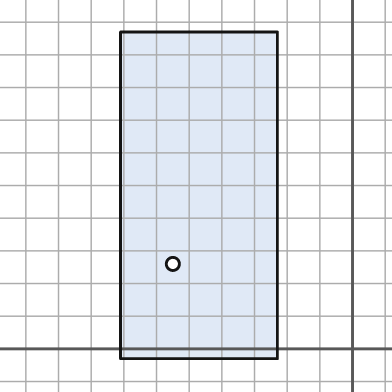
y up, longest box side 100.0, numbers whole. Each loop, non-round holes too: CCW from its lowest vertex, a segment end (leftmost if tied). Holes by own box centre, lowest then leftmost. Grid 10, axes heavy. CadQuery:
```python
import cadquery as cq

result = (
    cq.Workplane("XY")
    .moveTo(-71.0, -3.0)
    .lineTo(-23.0, -3.0)
    .lineTo(-23.0, 97.0)
    .lineTo(-71.0, 97.0)
    .close()
    .moveTo(-55.0, 26.0)
    .circle(2.0)
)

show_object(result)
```